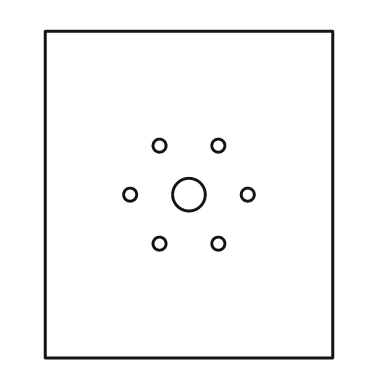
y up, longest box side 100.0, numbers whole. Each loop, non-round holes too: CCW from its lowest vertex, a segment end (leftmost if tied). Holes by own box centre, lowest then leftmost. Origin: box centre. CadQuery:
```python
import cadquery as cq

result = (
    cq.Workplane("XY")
    .moveTo(-44.0, -50.0)
    .lineTo(44.0, -50.0)
    .lineTo(44.0, 50.0)
    .lineTo(-44.0, 50.0)
    .close()
    .moveTo(-9.0, -15.0)
    .circle(2.0)
    .moveTo(9.0, -15.0)
    .circle(2.0)
    .moveTo(-18.0, 0.0)
    .circle(2.0)
    .moveTo(0.0, 0.0)
    .circle(5.0)
    .moveTo(18.0, 0.0)
    .circle(2.0)
    .moveTo(-9.0, 15.0)
    .circle(2.0)
    .moveTo(9.0, 15.0)
    .circle(2.0)
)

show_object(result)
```